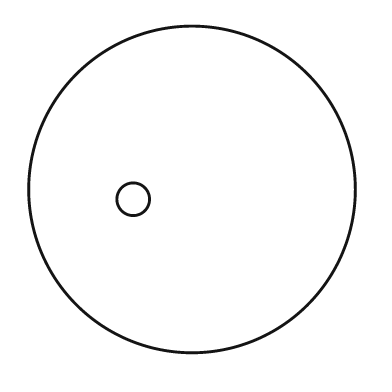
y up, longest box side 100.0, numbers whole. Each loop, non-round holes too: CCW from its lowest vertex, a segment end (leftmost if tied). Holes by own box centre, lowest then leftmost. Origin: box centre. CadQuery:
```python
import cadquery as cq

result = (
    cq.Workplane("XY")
    .moveTo(0.0, 0.0)
    .circle(50.0)
    .moveTo(-18.0, -3.0)
    .circle(5.0)
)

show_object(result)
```